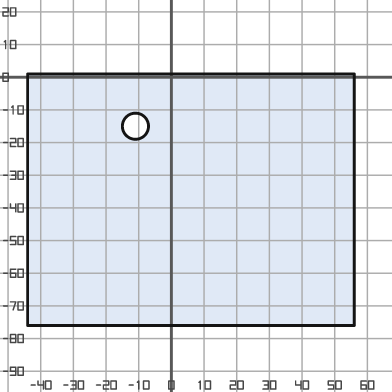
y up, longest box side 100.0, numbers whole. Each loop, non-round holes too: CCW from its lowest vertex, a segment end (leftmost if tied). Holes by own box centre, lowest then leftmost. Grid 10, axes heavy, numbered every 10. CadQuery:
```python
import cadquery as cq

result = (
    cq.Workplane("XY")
    .moveTo(-44.0, -76.0)
    .lineTo(56.0, -76.0)
    .lineTo(56.0, 1.0)
    .lineTo(-44.0, 1.0)
    .close()
    .moveTo(-11.0, -15.0)
    .circle(4.0)
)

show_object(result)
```